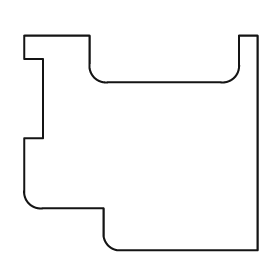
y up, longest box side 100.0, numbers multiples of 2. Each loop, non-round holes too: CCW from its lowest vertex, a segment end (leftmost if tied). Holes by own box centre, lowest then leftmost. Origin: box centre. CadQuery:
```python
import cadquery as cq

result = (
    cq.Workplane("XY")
    .moveTo(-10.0, -46.0)
    .lineTo(50.0, -46.0)
    .lineTo(50.0, 46.0)
    .lineTo(42.0, 46.0)
    .lineTo(42.0, 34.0)
    .threePointArc((40.0, 28.0), (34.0, 26.0))
    .lineTo(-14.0, 26.0)
    .threePointArc((-20.0, 28.0), (-22.0, 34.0))
    .lineTo(-22.0, 46.0)
    .lineTo(-50.0, 46.0)
    .lineTo(-50.0, 36.0)
    .lineTo(-42.0, 36.0)
    .lineTo(-42.0, 2.0)
    .lineTo(-50.0, 2.0)
    .lineTo(-50.0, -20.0)
    .threePointArc((-48.0, -26.0), (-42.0, -28.0))
    .lineTo(-16.0, -28.0)
    .lineTo(-16.0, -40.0)
    .threePointArc((-14.0, -44.0), (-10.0, -46.0))
    .close()
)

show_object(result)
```